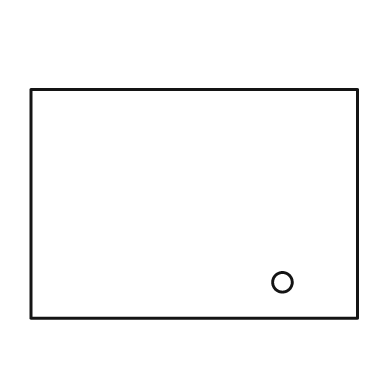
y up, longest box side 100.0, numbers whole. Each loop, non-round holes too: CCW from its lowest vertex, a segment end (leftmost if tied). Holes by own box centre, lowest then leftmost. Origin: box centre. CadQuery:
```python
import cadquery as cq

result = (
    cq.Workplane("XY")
    .moveTo(-50.0, -35.0)
    .lineTo(50.0, -35.0)
    .lineTo(50.0, 35.0)
    .lineTo(-50.0, 35.0)
    .close()
    .moveTo(27.0, -24.0)
    .circle(3.0)
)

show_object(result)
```